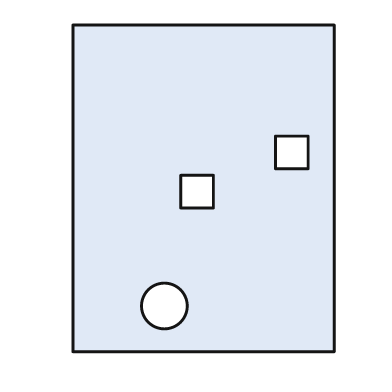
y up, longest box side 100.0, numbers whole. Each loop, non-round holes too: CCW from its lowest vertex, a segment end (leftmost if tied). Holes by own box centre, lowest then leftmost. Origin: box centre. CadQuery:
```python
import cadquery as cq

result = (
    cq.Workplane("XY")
    .moveTo(-40.0, -50.0)
    .lineTo(40.0, -50.0)
    .lineTo(40.0, 50.0)
    .lineTo(-40.0, 50.0)
    .close()
    .moveTo(-12.0, -36.0)
    .circle(7.0)
    .moveTo(-7.0, -6.0)
    .lineTo(3.0, -6.0)
    .lineTo(3.0, 4.0)
    .lineTo(-7.0, 4.0)
    .close()
    .moveTo(22.0, 6.0)
    .lineTo(32.0, 6.0)
    .lineTo(32.0, 16.0)
    .lineTo(22.0, 16.0)
    .close()
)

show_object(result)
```